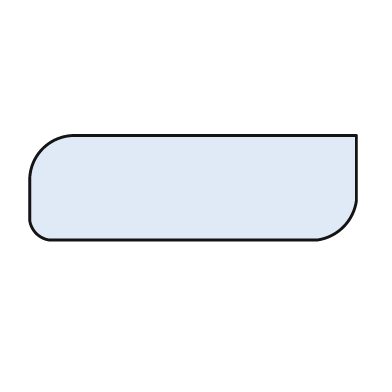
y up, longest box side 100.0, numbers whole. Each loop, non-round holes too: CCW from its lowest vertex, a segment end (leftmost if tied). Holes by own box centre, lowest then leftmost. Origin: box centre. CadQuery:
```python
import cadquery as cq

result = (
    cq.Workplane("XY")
    .moveTo(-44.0, -16.0)
    .lineTo(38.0, -16.0)
    .threePointArc((46.0, -12.0), (50.0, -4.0))
    .lineTo(50.0, 16.0)
    .lineTo(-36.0, 16.0)
    .threePointArc((-46.0, 12.0), (-50.0, 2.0))
    .lineTo(-50.0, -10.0)
    .threePointArc((-48.0, -14.0), (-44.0, -16.0))
    .close()
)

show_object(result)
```